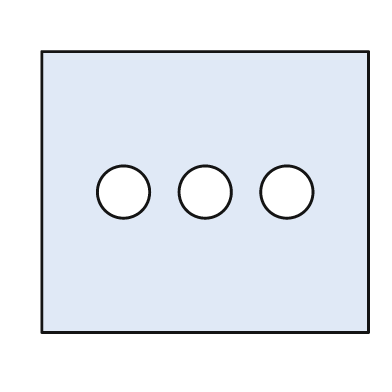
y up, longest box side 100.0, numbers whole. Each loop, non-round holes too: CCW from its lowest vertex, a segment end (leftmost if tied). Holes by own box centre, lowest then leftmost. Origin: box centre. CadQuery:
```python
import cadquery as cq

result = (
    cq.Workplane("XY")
    .moveTo(-50.0, -43.0)
    .lineTo(50.0, -43.0)
    .lineTo(50.0, 43.0)
    .lineTo(-50.0, 43.0)
    .close()
    .moveTo(-25.0, 0.0)
    .circle(8.0)
    .moveTo(0.0, 0.0)
    .circle(8.0)
    .moveTo(25.0, 0.0)
    .circle(8.0)
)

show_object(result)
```